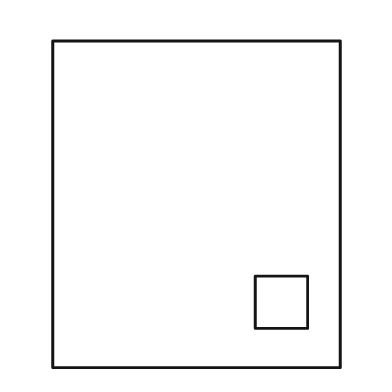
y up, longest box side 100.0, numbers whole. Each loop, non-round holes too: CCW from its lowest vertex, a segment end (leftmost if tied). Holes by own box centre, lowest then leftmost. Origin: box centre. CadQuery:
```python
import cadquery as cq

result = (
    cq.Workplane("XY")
    .moveTo(-44.0, -50.0)
    .lineTo(44.0, -50.0)
    .lineTo(44.0, 50.0)
    .lineTo(-44.0, 50.0)
    .close()
    .moveTo(18.0, -38.0)
    .lineTo(34.0, -38.0)
    .lineTo(34.0, -22.0)
    .lineTo(18.0, -22.0)
    .close()
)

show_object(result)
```